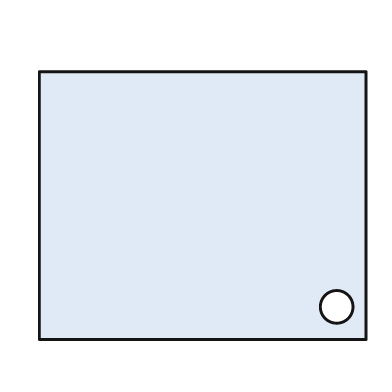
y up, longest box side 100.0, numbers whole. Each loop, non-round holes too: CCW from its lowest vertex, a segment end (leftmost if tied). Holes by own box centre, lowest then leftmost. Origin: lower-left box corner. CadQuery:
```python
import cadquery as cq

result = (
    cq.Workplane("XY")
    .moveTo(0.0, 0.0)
    .lineTo(100.0, 0.0)
    .lineTo(100.0, 82.0)
    .lineTo(0.0, 82.0)
    .close()
    .moveTo(91.0, 10.0)
    .circle(5.0)
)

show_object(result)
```